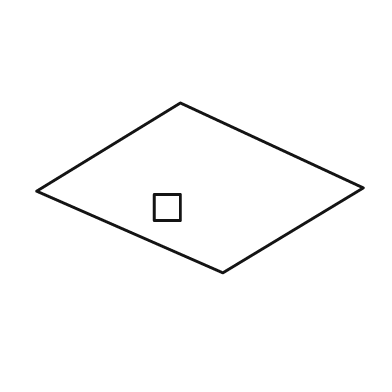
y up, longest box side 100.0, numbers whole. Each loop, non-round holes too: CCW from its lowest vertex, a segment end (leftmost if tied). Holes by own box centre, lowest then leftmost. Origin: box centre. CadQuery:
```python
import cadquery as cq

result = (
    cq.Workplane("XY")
    .moveTo(7.0, -26.0)
    .lineTo(50.0, 0.0)
    .lineTo(-6.0, 26.0)
    .lineTo(-50.0, -1.0)
    .close()
    .moveTo(-14.0, -10.0)
    .lineTo(-6.0, -10.0)
    .lineTo(-6.0, -2.0)
    .lineTo(-14.0, -2.0)
    .close()
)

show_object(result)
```